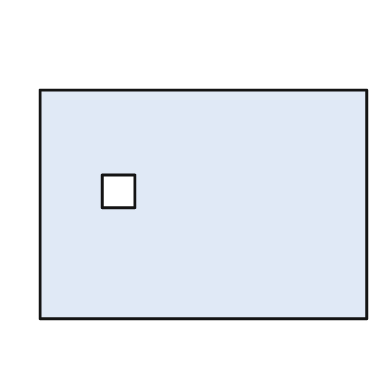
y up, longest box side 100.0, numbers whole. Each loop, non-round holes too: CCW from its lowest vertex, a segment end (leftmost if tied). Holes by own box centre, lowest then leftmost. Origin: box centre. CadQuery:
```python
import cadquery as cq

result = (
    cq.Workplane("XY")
    .moveTo(-50.0, -35.0)
    .lineTo(50.0, -35.0)
    .lineTo(50.0, 35.0)
    .lineTo(-50.0, 35.0)
    .close()
    .moveTo(-31.0, -1.0)
    .lineTo(-21.0, -1.0)
    .lineTo(-21.0, 9.0)
    .lineTo(-31.0, 9.0)
    .close()
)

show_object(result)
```